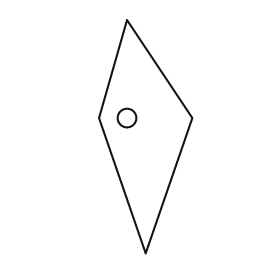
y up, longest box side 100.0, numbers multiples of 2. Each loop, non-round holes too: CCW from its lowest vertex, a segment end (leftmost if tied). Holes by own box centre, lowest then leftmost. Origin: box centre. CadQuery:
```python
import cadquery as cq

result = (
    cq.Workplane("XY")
    .moveTo(0.0, -50.0)
    .lineTo(20.0, 8.0)
    .lineTo(-8.0, 50.0)
    .lineTo(-20.0, 8.0)
    .close()
    .moveTo(-8.0, 8.0)
    .circle(4.0)
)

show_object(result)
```